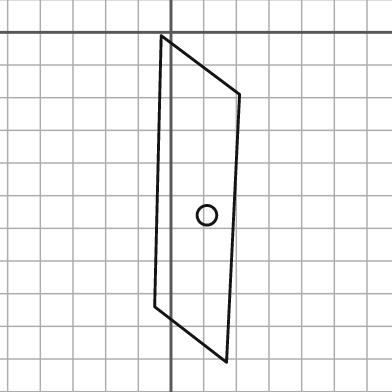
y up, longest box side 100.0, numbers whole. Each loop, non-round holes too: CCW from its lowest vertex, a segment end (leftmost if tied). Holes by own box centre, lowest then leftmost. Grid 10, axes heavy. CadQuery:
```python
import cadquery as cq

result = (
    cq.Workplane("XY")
    .moveTo(17.0, -101.0)
    .lineTo(21.0, -19.0)
    .lineTo(-3.0, -1.0)
    .lineTo(-5.0, -84.0)
    .close()
    .moveTo(11.0, -56.0)
    .circle(3.0)
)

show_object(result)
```